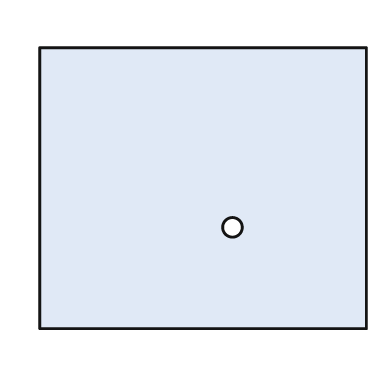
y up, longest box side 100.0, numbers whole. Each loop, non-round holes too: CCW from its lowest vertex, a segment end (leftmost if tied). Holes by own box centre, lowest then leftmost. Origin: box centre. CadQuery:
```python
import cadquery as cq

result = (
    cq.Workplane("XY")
    .moveTo(-50.0, -43.0)
    .lineTo(50.0, -43.0)
    .lineTo(50.0, 43.0)
    .lineTo(-50.0, 43.0)
    .close()
    .moveTo(9.0, -12.0)
    .circle(3.0)
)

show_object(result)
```